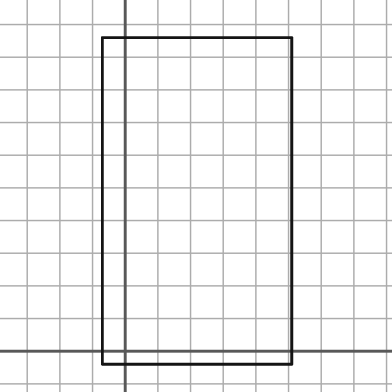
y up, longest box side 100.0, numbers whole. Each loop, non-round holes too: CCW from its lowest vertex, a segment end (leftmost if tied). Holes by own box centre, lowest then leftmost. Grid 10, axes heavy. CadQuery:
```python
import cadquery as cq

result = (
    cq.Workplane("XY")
    .moveTo(-7.0, -4.0)
    .lineTo(51.0, -4.0)
    .lineTo(51.0, 96.0)
    .lineTo(-7.0, 96.0)
    .close()
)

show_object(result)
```